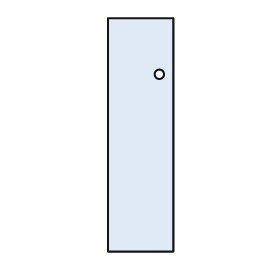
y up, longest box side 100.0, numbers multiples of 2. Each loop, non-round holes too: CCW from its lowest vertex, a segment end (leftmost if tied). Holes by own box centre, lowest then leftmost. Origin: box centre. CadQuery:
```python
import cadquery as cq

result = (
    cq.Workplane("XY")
    .moveTo(-14.0, -50.0)
    .lineTo(14.0, -50.0)
    .lineTo(14.0, 50.0)
    .lineTo(-14.0, 50.0)
    .close()
    .moveTo(8.0, 26.0)
    .circle(2.0)
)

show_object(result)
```